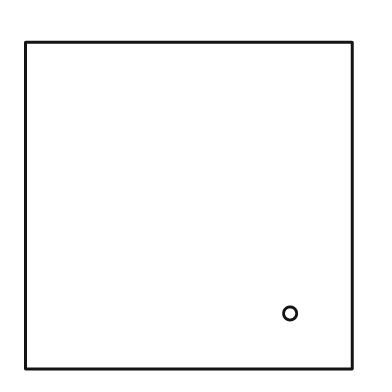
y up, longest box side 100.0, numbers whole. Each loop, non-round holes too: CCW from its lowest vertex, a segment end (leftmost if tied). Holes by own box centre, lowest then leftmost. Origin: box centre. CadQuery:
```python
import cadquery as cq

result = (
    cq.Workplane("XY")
    .moveTo(-50.0, -50.0)
    .lineTo(50.0, -50.0)
    .lineTo(50.0, 50.0)
    .lineTo(-50.0, 50.0)
    .close()
    .moveTo(31.0, -33.0)
    .circle(2.0)
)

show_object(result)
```